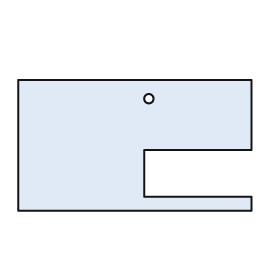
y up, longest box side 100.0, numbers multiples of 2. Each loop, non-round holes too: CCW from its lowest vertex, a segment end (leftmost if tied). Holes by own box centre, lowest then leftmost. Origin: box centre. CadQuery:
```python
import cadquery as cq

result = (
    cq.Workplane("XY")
    .moveTo(-50.0, -28.0)
    .lineTo(50.0, -28.0)
    .lineTo(50.0, -22.0)
    .lineTo(4.0, -22.0)
    .lineTo(4.0, -2.0)
    .lineTo(50.0, -2.0)
    .lineTo(50.0, 28.0)
    .lineTo(-50.0, 28.0)
    .close()
    .moveTo(6.0, 20.0)
    .circle(2.0)
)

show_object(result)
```